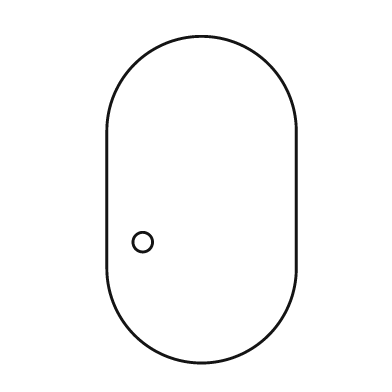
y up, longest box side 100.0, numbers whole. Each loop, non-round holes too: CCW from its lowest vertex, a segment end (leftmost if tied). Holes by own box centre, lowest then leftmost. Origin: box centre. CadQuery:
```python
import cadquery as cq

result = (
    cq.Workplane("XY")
    .moveTo(-29.0, -21.0)
    .threePointArc((0.0, -50.0), (29.0, -21.0))
    .lineTo(29.0, 21.0)
    .threePointArc((0.0, 50.0), (-29.0, 21.0))
    .close()
    .moveTo(-18.0, -13.0)
    .circle(3.0)
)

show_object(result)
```